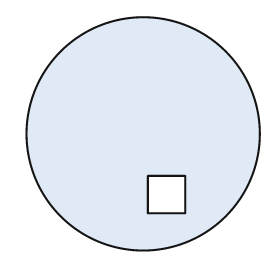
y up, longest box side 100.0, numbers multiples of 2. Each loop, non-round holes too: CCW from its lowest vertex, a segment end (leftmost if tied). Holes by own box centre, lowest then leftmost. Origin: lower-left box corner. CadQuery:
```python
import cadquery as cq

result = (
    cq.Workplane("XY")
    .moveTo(50.0, 50.0)
    .circle(50.0)
    .moveTo(52.0, 16.0)
    .lineTo(68.0, 16.0)
    .lineTo(68.0, 32.0)
    .lineTo(52.0, 32.0)
    .close()
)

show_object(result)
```